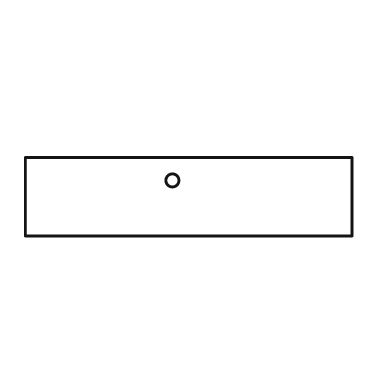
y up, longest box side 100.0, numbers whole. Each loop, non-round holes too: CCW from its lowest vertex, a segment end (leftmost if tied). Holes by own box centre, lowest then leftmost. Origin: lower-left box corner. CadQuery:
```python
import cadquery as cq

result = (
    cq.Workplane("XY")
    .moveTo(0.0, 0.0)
    .lineTo(100.0, 0.0)
    .lineTo(100.0, 24.0)
    .lineTo(0.0, 24.0)
    .close()
    .moveTo(45.0, 17.0)
    .circle(2.0)
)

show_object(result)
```